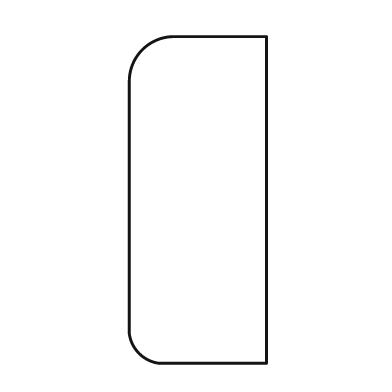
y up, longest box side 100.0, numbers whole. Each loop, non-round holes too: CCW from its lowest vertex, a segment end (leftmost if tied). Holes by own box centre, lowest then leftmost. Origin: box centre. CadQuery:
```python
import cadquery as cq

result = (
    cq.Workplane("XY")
    .moveTo(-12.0, -50.0)
    .lineTo(21.0, -50.0)
    .lineTo(21.0, 50.0)
    .lineTo(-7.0, 50.0)
    .threePointArc((-17.0, 46.0), (-21.0, 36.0))
    .lineTo(-21.0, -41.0)
    .threePointArc((-18.0, -47.0), (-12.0, -50.0))
    .close()
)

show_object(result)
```